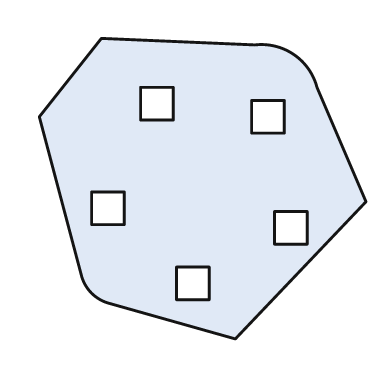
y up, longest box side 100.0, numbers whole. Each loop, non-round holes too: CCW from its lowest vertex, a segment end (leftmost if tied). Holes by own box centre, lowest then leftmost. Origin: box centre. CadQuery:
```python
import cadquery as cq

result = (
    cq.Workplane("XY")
    .moveTo(10.0, -46.0)
    .lineTo(50.0, -4.0)
    .lineTo(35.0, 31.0)
    .threePointArc((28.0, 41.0), (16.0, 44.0))
    .lineTo(-31.0, 46.0)
    .lineTo(-50.0, 22.0)
    .lineTo(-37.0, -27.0)
    .threePointArc((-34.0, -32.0), (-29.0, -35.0))
    .close()
    .moveTo(-8.0, -34.0)
    .lineTo(2.0, -34.0)
    .lineTo(2.0, -24.0)
    .lineTo(-8.0, -24.0)
    .close()
    .moveTo(22.0, -17.0)
    .lineTo(32.0, -17.0)
    .lineTo(32.0, -7.0)
    .lineTo(22.0, -7.0)
    .close()
    .moveTo(-34.0, -11.0)
    .lineTo(-24.0, -11.0)
    .lineTo(-24.0, -1.0)
    .lineTo(-34.0, -1.0)
    .close()
    .moveTo(15.0, 17.0)
    .lineTo(25.0, 17.0)
    .lineTo(25.0, 27.0)
    .lineTo(15.0, 27.0)
    .close()
    .moveTo(-19.0, 21.0)
    .lineTo(-9.0, 21.0)
    .lineTo(-9.0, 31.0)
    .lineTo(-19.0, 31.0)
    .close()
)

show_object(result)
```